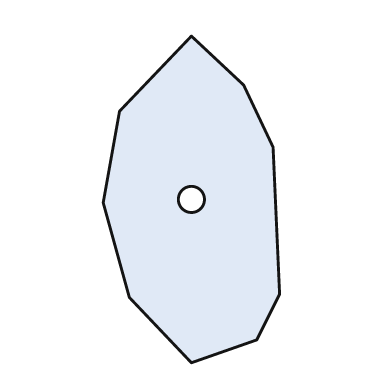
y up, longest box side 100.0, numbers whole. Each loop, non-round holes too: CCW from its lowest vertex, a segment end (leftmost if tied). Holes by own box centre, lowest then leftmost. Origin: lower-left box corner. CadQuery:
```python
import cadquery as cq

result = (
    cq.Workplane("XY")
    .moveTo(27.0, 0.0)
    .lineTo(47.0, 7.0)
    .lineTo(54.0, 21.0)
    .lineTo(52.0, 66.0)
    .lineTo(43.0, 85.0)
    .lineTo(27.0, 100.0)
    .lineTo(5.0, 77.0)
    .lineTo(0.0, 49.0)
    .lineTo(8.0, 20.0)
    .close()
    .moveTo(27.0, 50.0)
    .circle(4.0)
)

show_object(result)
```